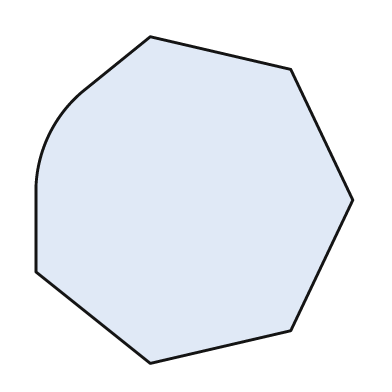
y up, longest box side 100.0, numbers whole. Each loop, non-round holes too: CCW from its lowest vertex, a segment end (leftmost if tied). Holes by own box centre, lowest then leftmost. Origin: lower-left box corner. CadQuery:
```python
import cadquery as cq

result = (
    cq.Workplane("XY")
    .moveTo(35.0, 0.0)
    .lineTo(78.0, 10.0)
    .lineTo(97.0, 50.0)
    .lineTo(78.0, 90.0)
    .lineTo(35.0, 100.0)
    .lineTo(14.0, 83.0)
    .threePointArc((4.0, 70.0), (0.0, 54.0))
    .lineTo(0.0, 28.0)
    .close()
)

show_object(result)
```